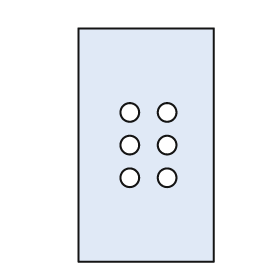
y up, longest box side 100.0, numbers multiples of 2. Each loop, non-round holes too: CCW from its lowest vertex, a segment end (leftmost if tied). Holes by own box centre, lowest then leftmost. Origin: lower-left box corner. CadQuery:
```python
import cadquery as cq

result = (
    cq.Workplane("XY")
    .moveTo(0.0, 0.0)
    .lineTo(58.0, 0.0)
    .lineTo(58.0, 100.0)
    .lineTo(0.0, 100.0)
    .close()
    .moveTo(22.0, 36.0)
    .circle(4.0)
    .moveTo(38.0, 36.0)
    .circle(4.0)
    .moveTo(22.0, 50.0)
    .circle(4.0)
    .moveTo(38.0, 50.0)
    .circle(4.0)
    .moveTo(22.0, 64.0)
    .circle(4.0)
    .moveTo(38.0, 64.0)
    .circle(4.0)
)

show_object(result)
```